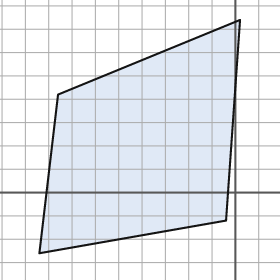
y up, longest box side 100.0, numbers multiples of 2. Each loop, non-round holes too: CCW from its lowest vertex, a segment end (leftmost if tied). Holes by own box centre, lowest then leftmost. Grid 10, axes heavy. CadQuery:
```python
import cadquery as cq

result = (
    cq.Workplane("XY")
    .moveTo(-84.0, -26.0)
    .lineTo(-4.0, -12.0)
    .lineTo(2.0, 74.0)
    .lineTo(-76.0, 42.0)
    .close()
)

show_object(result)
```